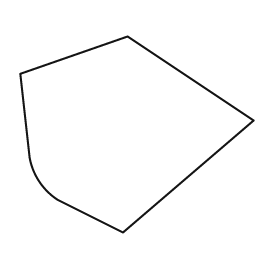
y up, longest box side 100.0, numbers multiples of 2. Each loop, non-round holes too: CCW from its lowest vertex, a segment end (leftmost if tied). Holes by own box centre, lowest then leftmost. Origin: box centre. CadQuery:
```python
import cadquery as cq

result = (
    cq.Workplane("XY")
    .moveTo(-6.0, -42.0)
    .lineTo(50.0, 6.0)
    .lineTo(-4.0, 42.0)
    .lineTo(-50.0, 26.0)
    .lineTo(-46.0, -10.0)
    .threePointArc((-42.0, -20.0), (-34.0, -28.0))
    .close()
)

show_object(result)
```